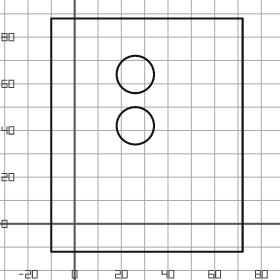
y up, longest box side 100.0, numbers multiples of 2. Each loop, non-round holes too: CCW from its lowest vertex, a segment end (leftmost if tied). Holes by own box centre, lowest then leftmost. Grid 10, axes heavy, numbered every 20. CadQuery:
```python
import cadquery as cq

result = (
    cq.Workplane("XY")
    .moveTo(-10.0, -12.0)
    .lineTo(72.0, -12.0)
    .lineTo(72.0, 88.0)
    .lineTo(-10.0, 88.0)
    .close()
    .moveTo(26.0, 42.0)
    .circle(8.0)
    .moveTo(26.0, 64.0)
    .circle(8.0)
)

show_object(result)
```